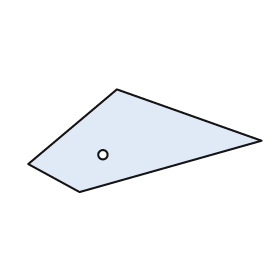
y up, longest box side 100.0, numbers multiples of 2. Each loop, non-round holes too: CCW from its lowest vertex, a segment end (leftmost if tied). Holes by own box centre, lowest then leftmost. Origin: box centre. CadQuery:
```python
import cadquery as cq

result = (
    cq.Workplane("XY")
    .moveTo(-28.0, -22.0)
    .lineTo(50.0, 0.0)
    .lineTo(-12.0, 22.0)
    .lineTo(-50.0, -10.0)
    .close()
    .moveTo(-18.0, -6.0)
    .circle(2.0)
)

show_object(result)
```